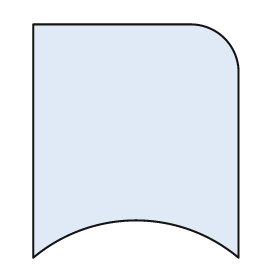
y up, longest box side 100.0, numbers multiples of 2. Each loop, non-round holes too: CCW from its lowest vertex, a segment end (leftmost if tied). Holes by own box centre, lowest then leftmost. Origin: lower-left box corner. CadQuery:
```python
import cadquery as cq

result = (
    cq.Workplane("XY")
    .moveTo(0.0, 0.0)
    .threePointArc((44.0, 16.0), (88.0, 0.0))
    .lineTo(88.0, 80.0)
    .threePointArc((82.0, 94.0), (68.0, 100.0))
    .lineTo(0.0, 100.0)
    .close()
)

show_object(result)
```